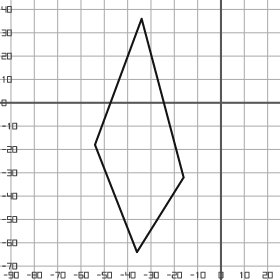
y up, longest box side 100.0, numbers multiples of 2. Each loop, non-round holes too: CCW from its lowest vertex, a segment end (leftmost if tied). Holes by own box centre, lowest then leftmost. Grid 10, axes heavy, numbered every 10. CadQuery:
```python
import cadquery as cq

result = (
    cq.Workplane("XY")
    .moveTo(-36.0, -64.0)
    .lineTo(-16.0, -32.0)
    .lineTo(-34.0, 36.0)
    .lineTo(-54.0, -18.0)
    .close()
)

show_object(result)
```